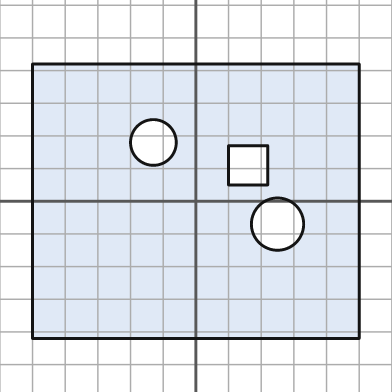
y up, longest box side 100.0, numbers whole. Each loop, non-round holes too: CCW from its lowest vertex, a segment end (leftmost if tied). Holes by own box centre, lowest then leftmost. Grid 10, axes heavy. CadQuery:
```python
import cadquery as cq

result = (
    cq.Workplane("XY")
    .moveTo(-50.0, -42.0)
    .lineTo(50.0, -42.0)
    .lineTo(50.0, 42.0)
    .lineTo(-50.0, 42.0)
    .close()
    .moveTo(25.0, -7.0)
    .circle(8.0)
    .moveTo(10.0, 5.0)
    .lineTo(22.0, 5.0)
    .lineTo(22.0, 17.0)
    .lineTo(10.0, 17.0)
    .close()
    .moveTo(-13.0, 18.0)
    .circle(7.0)
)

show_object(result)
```